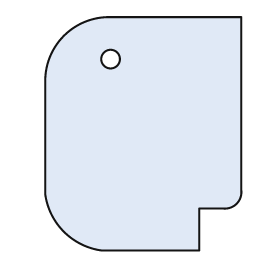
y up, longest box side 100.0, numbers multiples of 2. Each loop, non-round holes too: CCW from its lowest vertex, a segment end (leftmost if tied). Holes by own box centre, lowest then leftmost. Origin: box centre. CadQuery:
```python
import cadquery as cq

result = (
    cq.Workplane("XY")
    .moveTo(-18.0, -50.0)
    .lineTo(24.0, -50.0)
    .lineTo(24.0, -32.0)
    .lineTo(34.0, -32.0)
    .threePointArc((40.0, -30.0), (42.0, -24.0))
    .lineTo(42.0, 50.0)
    .lineTo(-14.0, 50.0)
    .threePointArc((-34.0, 42.0), (-42.0, 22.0))
    .lineTo(-42.0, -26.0)
    .threePointArc((-34.0, -42.0), (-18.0, -50.0))
    .close()
    .moveTo(-14.0, 32.0)
    .circle(4.0)
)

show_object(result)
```